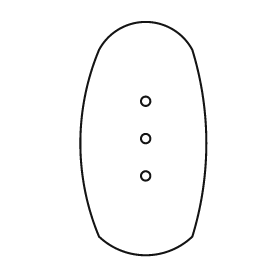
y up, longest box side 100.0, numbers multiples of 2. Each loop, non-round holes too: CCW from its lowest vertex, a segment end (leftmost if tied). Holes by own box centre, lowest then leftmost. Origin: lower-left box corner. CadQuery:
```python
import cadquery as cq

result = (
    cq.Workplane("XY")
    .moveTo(8.0, 8.0)
    .threePointArc((28.0, 0.0), (48.0, 8.0))
    .threePointArc((54.0, 48.0), (48.0, 88.0))
    .threePointArc((28.0, 100.0), (8.0, 88.0))
    .threePointArc((0.0, 48.0), (8.0, 8.0))
    .close()
    .moveTo(28.0, 34.0)
    .circle(2.0)
    .moveTo(28.0, 50.0)
    .circle(2.0)
    .moveTo(28.0, 66.0)
    .circle(2.0)
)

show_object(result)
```